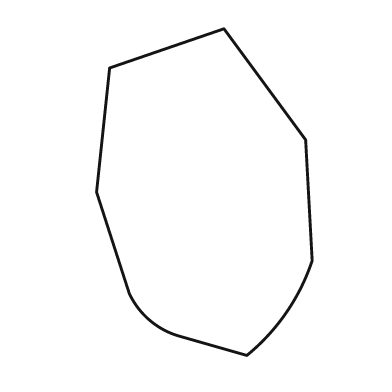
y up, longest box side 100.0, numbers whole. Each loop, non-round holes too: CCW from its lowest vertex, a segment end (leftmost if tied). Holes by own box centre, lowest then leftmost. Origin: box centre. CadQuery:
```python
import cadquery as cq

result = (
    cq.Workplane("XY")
    .moveTo(13.0, -50.0)
    .threePointArc((25.0, -37.0), (33.0, -21.0))
    .lineTo(31.0, 16.0)
    .lineTo(6.0, 50.0)
    .lineTo(-29.0, 38.0)
    .lineTo(-33.0, 0.0)
    .lineTo(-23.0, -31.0)
    .threePointArc((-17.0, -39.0), (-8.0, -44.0))
    .close()
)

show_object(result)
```